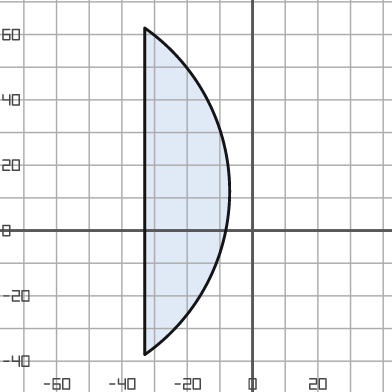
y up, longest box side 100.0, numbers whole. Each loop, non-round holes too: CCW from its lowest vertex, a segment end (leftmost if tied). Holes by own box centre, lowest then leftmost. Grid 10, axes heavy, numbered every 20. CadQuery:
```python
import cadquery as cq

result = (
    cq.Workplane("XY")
    .moveTo(-33.0, -38.0)
    .threePointArc((-7.0, 12.0), (-33.0, 62.0))
    .close()
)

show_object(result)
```